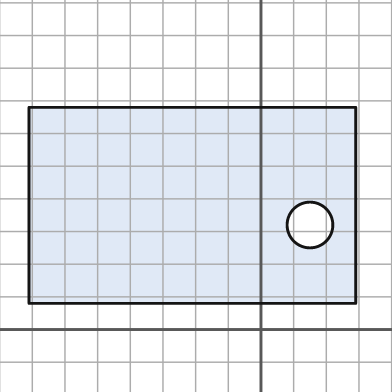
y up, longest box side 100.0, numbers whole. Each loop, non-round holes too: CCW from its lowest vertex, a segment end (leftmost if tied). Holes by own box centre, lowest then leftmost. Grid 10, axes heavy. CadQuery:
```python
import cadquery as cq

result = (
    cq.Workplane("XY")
    .moveTo(-71.0, 8.0)
    .lineTo(29.0, 8.0)
    .lineTo(29.0, 68.0)
    .lineTo(-71.0, 68.0)
    .close()
    .moveTo(15.0, 32.0)
    .circle(7.0)
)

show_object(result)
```